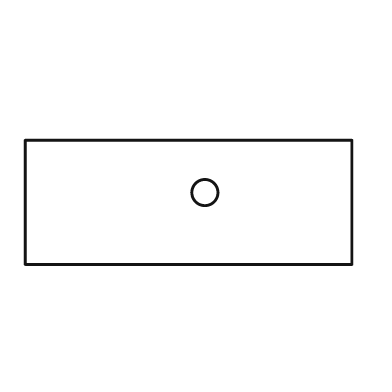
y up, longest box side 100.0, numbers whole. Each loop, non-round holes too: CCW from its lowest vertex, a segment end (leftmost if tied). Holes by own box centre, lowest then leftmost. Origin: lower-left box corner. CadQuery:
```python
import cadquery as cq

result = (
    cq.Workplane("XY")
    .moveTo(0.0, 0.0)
    .lineTo(100.0, 0.0)
    .lineTo(100.0, 38.0)
    .lineTo(0.0, 38.0)
    .close()
    .moveTo(55.0, 22.0)
    .circle(4.0)
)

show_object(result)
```